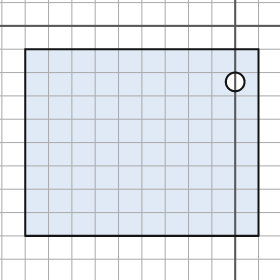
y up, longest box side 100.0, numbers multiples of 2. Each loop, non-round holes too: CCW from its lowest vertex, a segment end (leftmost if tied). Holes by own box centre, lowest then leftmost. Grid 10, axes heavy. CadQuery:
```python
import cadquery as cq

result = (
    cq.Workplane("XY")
    .moveTo(-90.0, -90.0)
    .lineTo(10.0, -90.0)
    .lineTo(10.0, -10.0)
    .lineTo(-90.0, -10.0)
    .close()
    .moveTo(0.0, -24.0)
    .circle(4.0)
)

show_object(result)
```